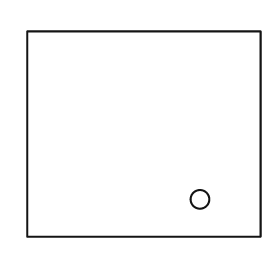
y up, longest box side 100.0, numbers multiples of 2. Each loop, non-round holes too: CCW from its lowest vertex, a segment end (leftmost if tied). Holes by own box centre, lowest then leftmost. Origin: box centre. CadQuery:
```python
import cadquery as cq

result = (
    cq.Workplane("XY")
    .moveTo(-50.0, -44.0)
    .lineTo(50.0, -44.0)
    .lineTo(50.0, 44.0)
    .lineTo(-50.0, 44.0)
    .close()
    .moveTo(24.0, -28.0)
    .circle(4.0)
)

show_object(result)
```